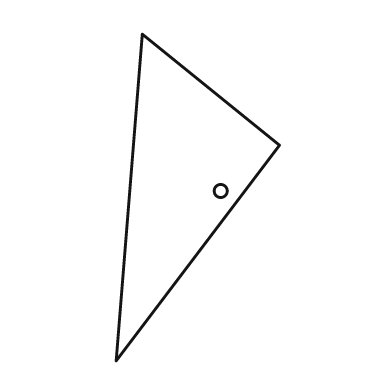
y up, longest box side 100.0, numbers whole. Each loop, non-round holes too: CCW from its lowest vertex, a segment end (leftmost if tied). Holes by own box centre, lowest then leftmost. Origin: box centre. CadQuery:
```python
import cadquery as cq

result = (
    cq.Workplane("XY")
    .moveTo(-25.0, -50.0)
    .lineTo(25.0, 16.0)
    .lineTo(-17.0, 50.0)
    .close()
    .moveTo(7.0, 2.0)
    .circle(2.0)
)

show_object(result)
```